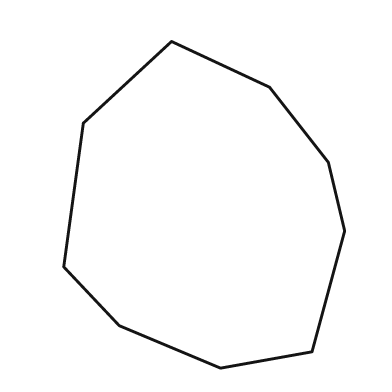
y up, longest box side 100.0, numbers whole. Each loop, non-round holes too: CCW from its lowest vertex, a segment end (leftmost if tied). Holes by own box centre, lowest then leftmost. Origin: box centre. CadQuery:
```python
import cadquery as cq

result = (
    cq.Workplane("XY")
    .moveTo(5.0, -50.0)
    .lineTo(33.0, -45.0)
    .lineTo(43.0, -8.0)
    .lineTo(38.0, 13.0)
    .lineTo(20.0, 36.0)
    .lineTo(-10.0, 50.0)
    .lineTo(-37.0, 25.0)
    .lineTo(-43.0, -19.0)
    .lineTo(-26.0, -37.0)
    .close()
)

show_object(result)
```